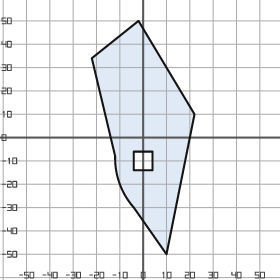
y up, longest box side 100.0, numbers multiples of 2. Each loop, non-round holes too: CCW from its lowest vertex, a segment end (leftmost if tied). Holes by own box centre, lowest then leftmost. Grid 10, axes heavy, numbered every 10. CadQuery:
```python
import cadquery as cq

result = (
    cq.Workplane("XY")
    .moveTo(10.0, -50.0)
    .lineTo(22.0, 10.0)
    .lineTo(-2.0, 50.0)
    .lineTo(-22.0, 34.0)
    .lineTo(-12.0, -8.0)
    .threePointArc((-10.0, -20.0), (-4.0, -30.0))
    .close()
    .moveTo(-4.0, -14.0)
    .lineTo(4.0, -14.0)
    .lineTo(4.0, -6.0)
    .lineTo(-4.0, -6.0)
    .close()
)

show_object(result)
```